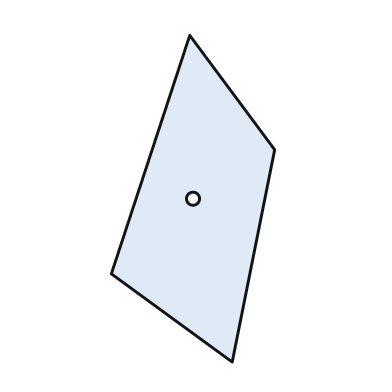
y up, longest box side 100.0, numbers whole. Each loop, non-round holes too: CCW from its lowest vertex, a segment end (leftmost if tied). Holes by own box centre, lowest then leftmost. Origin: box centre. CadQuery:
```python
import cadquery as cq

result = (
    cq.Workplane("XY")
    .moveTo(12.0, -50.0)
    .lineTo(25.0, 15.0)
    .lineTo(-1.0, 50.0)
    .lineTo(-25.0, -23.0)
    .close()
    .moveTo(0.0, 0.0)
    .circle(2.0)
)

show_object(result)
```